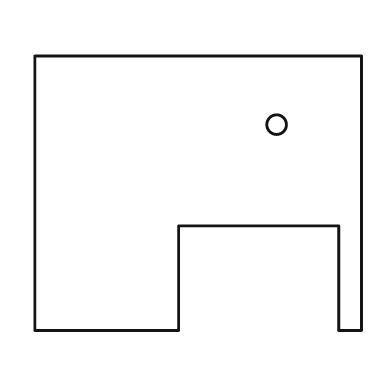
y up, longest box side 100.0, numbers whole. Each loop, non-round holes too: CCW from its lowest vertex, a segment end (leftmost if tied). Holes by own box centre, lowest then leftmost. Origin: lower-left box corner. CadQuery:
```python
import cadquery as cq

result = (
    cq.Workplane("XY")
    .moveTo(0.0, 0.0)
    .lineTo(44.0, 0.0)
    .lineTo(44.0, 32.0)
    .lineTo(93.0, 32.0)
    .lineTo(93.0, 0.0)
    .lineTo(100.0, 0.0)
    .lineTo(100.0, 84.0)
    .lineTo(0.0, 84.0)
    .close()
    .moveTo(74.0, 63.0)
    .circle(3.0)
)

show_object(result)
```